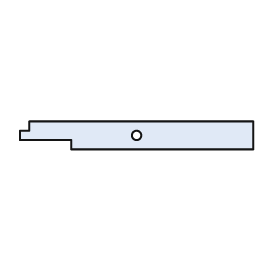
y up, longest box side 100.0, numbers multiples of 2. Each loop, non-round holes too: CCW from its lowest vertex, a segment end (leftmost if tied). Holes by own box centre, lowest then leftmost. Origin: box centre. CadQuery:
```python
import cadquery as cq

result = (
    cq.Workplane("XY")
    .moveTo(-28.0, -6.0)
    .lineTo(50.0, -6.0)
    .lineTo(50.0, 6.0)
    .lineTo(-46.0, 6.0)
    .lineTo(-46.0, 2.0)
    .lineTo(-50.0, 2.0)
    .lineTo(-50.0, -2.0)
    .lineTo(-28.0, -2.0)
    .close()
    .moveTo(0.0, 0.0)
    .circle(2.0)
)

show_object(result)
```